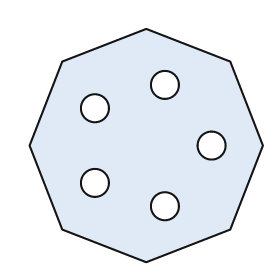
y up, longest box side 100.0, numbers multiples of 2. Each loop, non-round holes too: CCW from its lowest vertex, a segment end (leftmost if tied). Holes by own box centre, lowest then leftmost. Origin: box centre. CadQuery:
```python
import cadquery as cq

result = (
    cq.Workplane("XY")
    .moveTo(0.0, -50.0)
    .lineTo(36.0, -36.0)
    .lineTo(50.0, 0.0)
    .lineTo(36.0, 36.0)
    .lineTo(0.0, 50.0)
    .lineTo(-36.0, 36.0)
    .lineTo(-50.0, 0.0)
    .lineTo(-36.0, -36.0)
    .close()
    .moveTo(8.0, -26.0)
    .circle(6.0)
    .moveTo(-22.0, -16.0)
    .circle(6.0)
    .moveTo(28.0, 0.0)
    .circle(6.0)
    .moveTo(-22.0, 16.0)
    .circle(6.0)
    .moveTo(8.0, 26.0)
    .circle(6.0)
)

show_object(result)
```